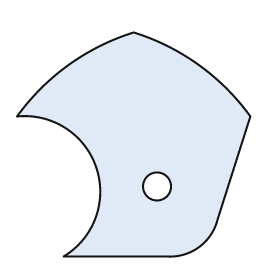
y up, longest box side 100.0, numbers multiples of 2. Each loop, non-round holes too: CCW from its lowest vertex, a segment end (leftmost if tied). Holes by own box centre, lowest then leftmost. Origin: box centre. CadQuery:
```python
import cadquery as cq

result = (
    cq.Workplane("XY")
    .moveTo(-30.0, -48.0)
    .lineTo(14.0, -48.0)
    .threePointArc((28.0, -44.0), (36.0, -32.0))
    .lineTo(50.0, 12.0)
    .threePointArc((28.0, 34.0), (0.0, 48.0))
    .threePointArc((-28.0, 34.0), (-50.0, 12.0))
    .threePointArc((-16.0, -10.0), (-30.0, -48.0))
    .close()
    .moveTo(10.0, -18.0)
    .circle(6.0)
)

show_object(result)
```